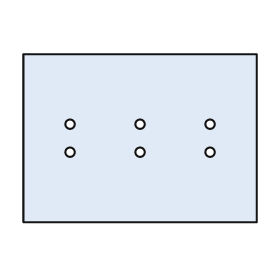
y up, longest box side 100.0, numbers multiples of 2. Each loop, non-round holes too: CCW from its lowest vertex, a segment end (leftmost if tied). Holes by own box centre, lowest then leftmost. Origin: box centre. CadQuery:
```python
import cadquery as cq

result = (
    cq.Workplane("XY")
    .moveTo(-50.0, -36.0)
    .lineTo(50.0, -36.0)
    .lineTo(50.0, 36.0)
    .lineTo(-50.0, 36.0)
    .close()
    .moveTo(-30.0, -6.0)
    .circle(2.0)
    .moveTo(0.0, -6.0)
    .circle(2.0)
    .moveTo(30.0, -6.0)
    .circle(2.0)
    .moveTo(-30.0, 6.0)
    .circle(2.0)
    .moveTo(0.0, 6.0)
    .circle(2.0)
    .moveTo(30.0, 6.0)
    .circle(2.0)
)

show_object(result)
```